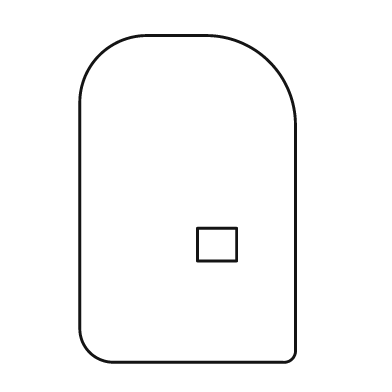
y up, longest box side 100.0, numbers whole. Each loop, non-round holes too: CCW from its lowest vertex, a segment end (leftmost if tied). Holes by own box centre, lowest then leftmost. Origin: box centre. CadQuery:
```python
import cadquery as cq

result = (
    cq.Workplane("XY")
    .moveTo(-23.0, -50.0)
    .lineTo(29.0, -50.0)
    .threePointArc((32.0, -49.0), (33.0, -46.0))
    .lineTo(33.0, 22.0)
    .threePointArc((25.0, 42.0), (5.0, 50.0))
    .lineTo(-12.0, 50.0)
    .threePointArc((-27.0, 44.0), (-33.0, 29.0))
    .lineTo(-33.0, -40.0)
    .threePointArc((-30.0, -47.0), (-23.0, -50.0))
    .close()
    .moveTo(3.0, -19.0)
    .lineTo(15.0, -19.0)
    .lineTo(15.0, -9.0)
    .lineTo(3.0, -9.0)
    .close()
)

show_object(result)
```